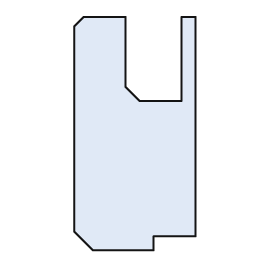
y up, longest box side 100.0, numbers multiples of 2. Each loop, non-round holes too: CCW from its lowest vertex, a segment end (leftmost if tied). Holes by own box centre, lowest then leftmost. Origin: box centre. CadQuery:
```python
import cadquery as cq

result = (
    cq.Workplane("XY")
    .moveTo(-18.0, -50.0)
    .lineTo(8.0, -50.0)
    .lineTo(8.0, -44.0)
    .lineTo(26.0, -44.0)
    .lineTo(26.0, 50.0)
    .lineTo(20.0, 50.0)
    .lineTo(20.0, 14.0)
    .lineTo(2.0, 14.0)
    .lineTo(-4.0, 20.0)
    .lineTo(-4.0, 50.0)
    .lineTo(-22.0, 50.0)
    .lineTo(-26.0, 46.0)
    .lineTo(-26.0, -42.0)
    .close()
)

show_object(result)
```